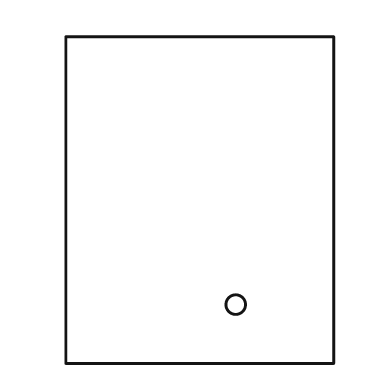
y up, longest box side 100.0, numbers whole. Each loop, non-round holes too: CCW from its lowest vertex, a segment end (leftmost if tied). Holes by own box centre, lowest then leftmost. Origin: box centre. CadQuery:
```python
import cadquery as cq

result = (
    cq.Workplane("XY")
    .moveTo(-41.0, -50.0)
    .lineTo(41.0, -50.0)
    .lineTo(41.0, 50.0)
    .lineTo(-41.0, 50.0)
    .close()
    .moveTo(11.0, -32.0)
    .circle(3.0)
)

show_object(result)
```